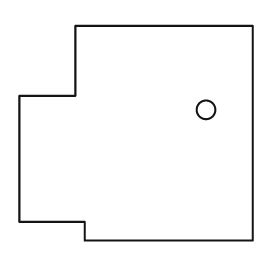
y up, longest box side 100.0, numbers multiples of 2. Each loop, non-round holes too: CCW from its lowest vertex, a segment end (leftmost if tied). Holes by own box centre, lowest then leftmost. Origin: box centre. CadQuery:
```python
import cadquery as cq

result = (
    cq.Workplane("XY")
    .moveTo(-22.0, -46.0)
    .lineTo(50.0, -46.0)
    .lineTo(50.0, 46.0)
    .lineTo(-26.0, 46.0)
    .lineTo(-26.0, 16.0)
    .lineTo(-50.0, 16.0)
    .lineTo(-50.0, -38.0)
    .lineTo(-22.0, -38.0)
    .close()
    .moveTo(30.0, 10.0)
    .circle(4.0)
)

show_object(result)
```